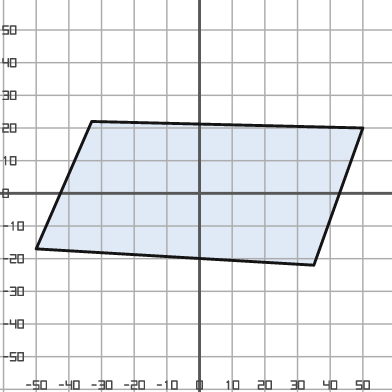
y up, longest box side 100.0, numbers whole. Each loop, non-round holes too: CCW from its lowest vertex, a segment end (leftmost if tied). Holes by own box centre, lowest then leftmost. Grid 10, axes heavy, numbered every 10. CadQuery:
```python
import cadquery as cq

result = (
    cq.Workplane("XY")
    .moveTo(35.0, -22.0)
    .lineTo(50.0, 20.0)
    .lineTo(-33.0, 22.0)
    .lineTo(-50.0, -17.0)
    .close()
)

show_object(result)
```